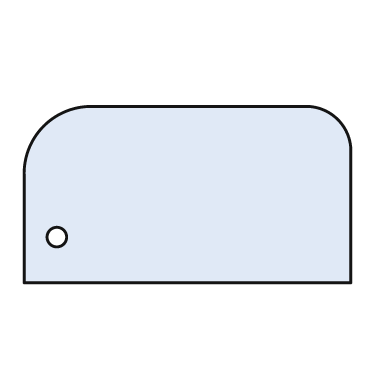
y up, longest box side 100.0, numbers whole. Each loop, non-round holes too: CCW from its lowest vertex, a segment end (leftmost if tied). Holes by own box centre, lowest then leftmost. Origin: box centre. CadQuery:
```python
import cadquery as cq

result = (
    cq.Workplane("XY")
    .moveTo(-50.0, -27.0)
    .lineTo(50.0, -27.0)
    .lineTo(50.0, 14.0)
    .threePointArc((46.0, 23.0), (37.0, 27.0))
    .lineTo(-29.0, 27.0)
    .threePointArc((-44.0, 21.0), (-50.0, 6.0))
    .close()
    .moveTo(-40.0, -13.0)
    .circle(3.0)
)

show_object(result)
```